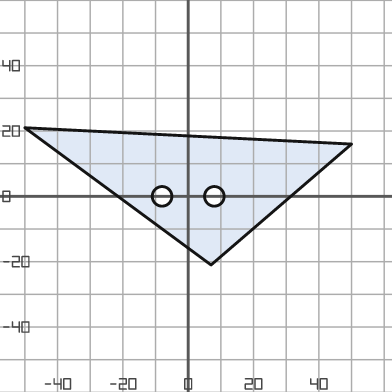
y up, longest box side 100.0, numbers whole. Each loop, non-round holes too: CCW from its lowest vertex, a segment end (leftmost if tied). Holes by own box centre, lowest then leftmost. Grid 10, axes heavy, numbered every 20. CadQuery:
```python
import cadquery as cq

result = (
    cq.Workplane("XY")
    .moveTo(7.0, -21.0)
    .lineTo(50.0, 16.0)
    .lineTo(-50.0, 21.0)
    .close()
    .moveTo(-8.0, 0.0)
    .circle(3.0)
    .moveTo(8.0, 0.0)
    .circle(3.0)
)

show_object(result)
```